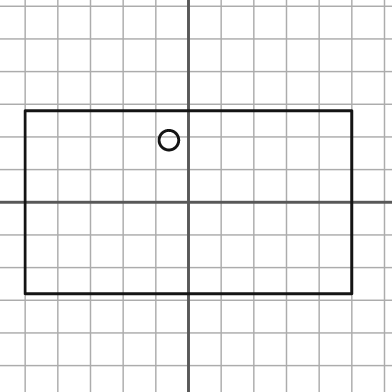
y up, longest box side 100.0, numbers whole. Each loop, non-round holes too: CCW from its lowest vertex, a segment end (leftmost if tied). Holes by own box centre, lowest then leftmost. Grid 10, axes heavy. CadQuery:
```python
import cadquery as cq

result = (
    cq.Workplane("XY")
    .moveTo(-50.0, -28.0)
    .lineTo(50.0, -28.0)
    .lineTo(50.0, 28.0)
    .lineTo(-50.0, 28.0)
    .close()
    .moveTo(-6.0, 19.0)
    .circle(3.0)
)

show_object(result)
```